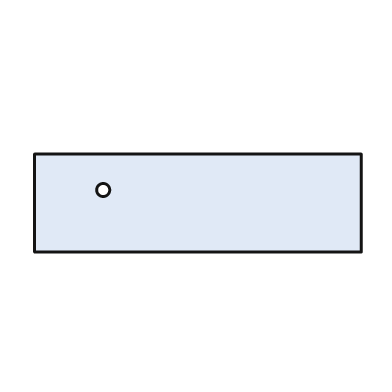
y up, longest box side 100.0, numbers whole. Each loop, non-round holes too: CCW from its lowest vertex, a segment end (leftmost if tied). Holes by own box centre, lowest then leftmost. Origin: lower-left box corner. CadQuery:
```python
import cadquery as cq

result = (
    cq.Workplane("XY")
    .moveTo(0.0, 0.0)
    .lineTo(100.0, 0.0)
    .lineTo(100.0, 30.0)
    .lineTo(0.0, 30.0)
    .close()
    .moveTo(21.0, 19.0)
    .circle(2.0)
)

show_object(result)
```